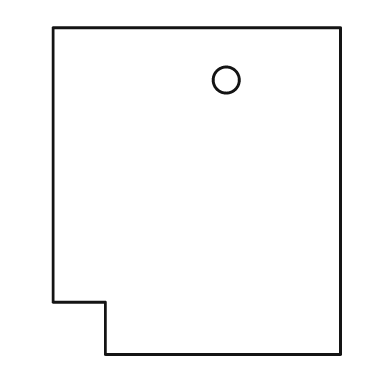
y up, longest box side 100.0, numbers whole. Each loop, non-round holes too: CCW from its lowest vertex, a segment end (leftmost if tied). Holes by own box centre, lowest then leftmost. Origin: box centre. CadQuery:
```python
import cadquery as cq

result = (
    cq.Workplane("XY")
    .moveTo(-28.0, -50.0)
    .lineTo(44.0, -50.0)
    .lineTo(44.0, 50.0)
    .lineTo(-44.0, 50.0)
    .lineTo(-44.0, -34.0)
    .lineTo(-28.0, -34.0)
    .close()
    .moveTo(9.0, 34.0)
    .circle(4.0)
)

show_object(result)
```